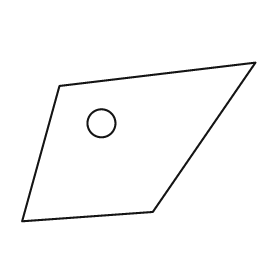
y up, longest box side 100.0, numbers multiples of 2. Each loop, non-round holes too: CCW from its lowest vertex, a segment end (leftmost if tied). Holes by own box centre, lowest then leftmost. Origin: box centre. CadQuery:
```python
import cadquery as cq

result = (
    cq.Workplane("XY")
    .moveTo(-50.0, -34.0)
    .lineTo(6.0, -30.0)
    .lineTo(50.0, 34.0)
    .lineTo(-34.0, 24.0)
    .close()
    .moveTo(-16.0, 8.0)
    .circle(6.0)
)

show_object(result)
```